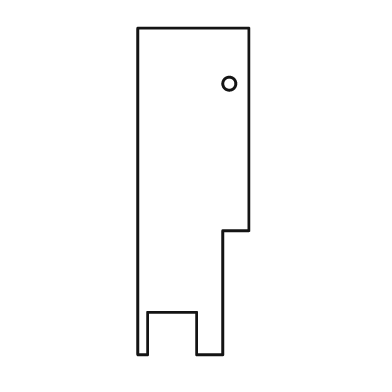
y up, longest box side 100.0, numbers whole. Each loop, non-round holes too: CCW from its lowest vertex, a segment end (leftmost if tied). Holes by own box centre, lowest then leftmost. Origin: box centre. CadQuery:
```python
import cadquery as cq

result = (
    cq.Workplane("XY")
    .moveTo(-17.0, -50.0)
    .lineTo(-14.0, -50.0)
    .lineTo(-14.0, -37.0)
    .lineTo(1.0, -37.0)
    .lineTo(1.0, -50.0)
    .lineTo(9.0, -50.0)
    .lineTo(9.0, -12.0)
    .lineTo(17.0, -12.0)
    .lineTo(17.0, 50.0)
    .lineTo(-17.0, 50.0)
    .close()
    .moveTo(11.0, 33.0)
    .circle(2.0)
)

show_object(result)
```